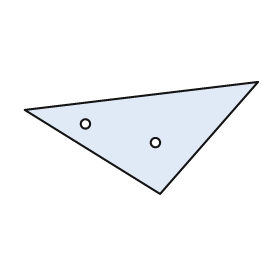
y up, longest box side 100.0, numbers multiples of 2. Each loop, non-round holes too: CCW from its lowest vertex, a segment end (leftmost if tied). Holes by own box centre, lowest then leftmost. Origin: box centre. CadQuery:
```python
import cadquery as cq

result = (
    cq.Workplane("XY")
    .moveTo(8.0, -24.0)
    .lineTo(50.0, 24.0)
    .lineTo(-50.0, 12.0)
    .close()
    .moveTo(6.0, -2.0)
    .circle(2.0)
    .moveTo(-24.0, 6.0)
    .circle(2.0)
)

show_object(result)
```